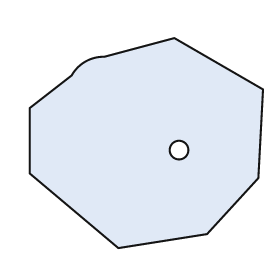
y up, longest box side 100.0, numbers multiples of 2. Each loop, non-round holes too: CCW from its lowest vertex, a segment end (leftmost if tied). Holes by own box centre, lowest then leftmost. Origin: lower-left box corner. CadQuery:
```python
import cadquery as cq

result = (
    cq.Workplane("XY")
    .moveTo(38.0, 0.0)
    .lineTo(76.0, 6.0)
    .lineTo(98.0, 30.0)
    .lineTo(100.0, 68.0)
    .lineTo(62.0, 90.0)
    .lineTo(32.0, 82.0)
    .threePointArc((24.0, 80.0), (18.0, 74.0))
    .lineTo(0.0, 60.0)
    .lineTo(0.0, 32.0)
    .close()
    .moveTo(64.0, 42.0)
    .circle(4.0)
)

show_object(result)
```